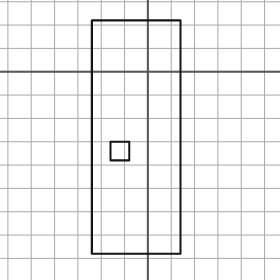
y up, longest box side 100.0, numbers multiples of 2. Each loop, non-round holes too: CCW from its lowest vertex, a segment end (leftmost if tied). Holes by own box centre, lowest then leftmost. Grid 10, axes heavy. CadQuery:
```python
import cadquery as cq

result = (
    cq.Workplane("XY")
    .moveTo(-24.0, -78.0)
    .lineTo(14.0, -78.0)
    .lineTo(14.0, 22.0)
    .lineTo(-24.0, 22.0)
    .close()
    .moveTo(-16.0, -38.0)
    .lineTo(-8.0, -38.0)
    .lineTo(-8.0, -30.0)
    .lineTo(-16.0, -30.0)
    .close()
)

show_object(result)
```